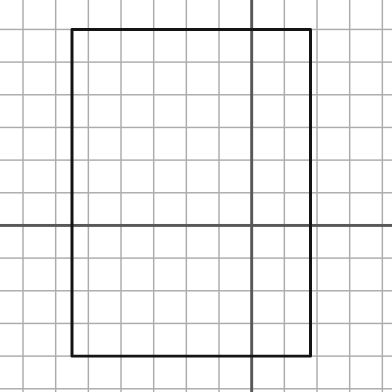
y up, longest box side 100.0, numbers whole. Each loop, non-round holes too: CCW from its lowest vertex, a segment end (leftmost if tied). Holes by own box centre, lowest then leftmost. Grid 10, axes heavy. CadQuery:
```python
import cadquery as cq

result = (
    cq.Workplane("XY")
    .moveTo(-55.0, -40.0)
    .lineTo(18.0, -40.0)
    .lineTo(18.0, 60.0)
    .lineTo(-55.0, 60.0)
    .close()
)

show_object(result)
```